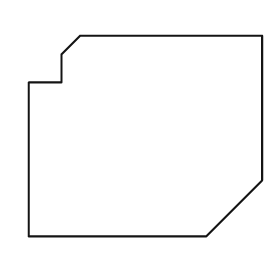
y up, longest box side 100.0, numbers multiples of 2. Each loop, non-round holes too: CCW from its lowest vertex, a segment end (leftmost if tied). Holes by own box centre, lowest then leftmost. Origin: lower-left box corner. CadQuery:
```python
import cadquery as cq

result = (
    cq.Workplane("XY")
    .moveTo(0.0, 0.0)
    .lineTo(76.0, 0.0)
    .lineTo(100.0, 24.0)
    .lineTo(100.0, 86.0)
    .lineTo(22.0, 86.0)
    .lineTo(14.0, 78.0)
    .lineTo(14.0, 66.0)
    .lineTo(0.0, 66.0)
    .close()
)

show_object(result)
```